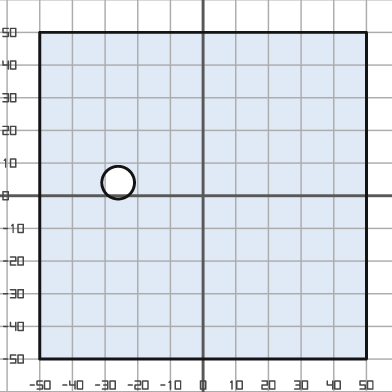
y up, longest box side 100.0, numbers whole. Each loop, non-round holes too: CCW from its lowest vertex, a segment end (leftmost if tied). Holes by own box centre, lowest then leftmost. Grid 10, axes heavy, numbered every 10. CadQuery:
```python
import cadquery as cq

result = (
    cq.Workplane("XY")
    .moveTo(-50.0, -50.0)
    .lineTo(50.0, -50.0)
    .lineTo(50.0, 50.0)
    .lineTo(-50.0, 50.0)
    .close()
    .moveTo(-26.0, 4.0)
    .circle(5.0)
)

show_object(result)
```